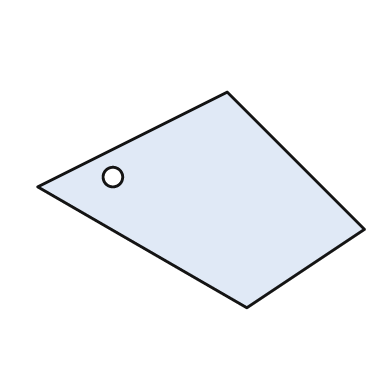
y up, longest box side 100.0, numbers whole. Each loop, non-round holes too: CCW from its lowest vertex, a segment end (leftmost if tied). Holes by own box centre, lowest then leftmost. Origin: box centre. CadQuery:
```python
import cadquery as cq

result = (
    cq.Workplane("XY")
    .moveTo(14.0, -33.0)
    .lineTo(50.0, -9.0)
    .lineTo(8.0, 33.0)
    .lineTo(-50.0, 4.0)
    .close()
    .moveTo(-27.0, 7.0)
    .circle(3.0)
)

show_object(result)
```